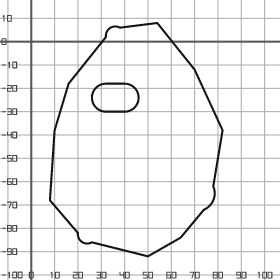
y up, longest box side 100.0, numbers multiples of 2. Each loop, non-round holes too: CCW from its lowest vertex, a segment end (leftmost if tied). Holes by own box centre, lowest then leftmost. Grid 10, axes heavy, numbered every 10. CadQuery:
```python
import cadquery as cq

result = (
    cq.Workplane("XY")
    .moveTo(50.0, -92.0)
    .lineTo(64.0, -84.0)
    .lineTo(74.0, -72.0)
    .threePointArc((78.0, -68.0), (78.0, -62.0))
    .lineTo(82.0, -38.0)
    .lineTo(70.0, -12.0)
    .lineTo(54.0, 8.0)
    .lineTo(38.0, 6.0)
    .threePointArc((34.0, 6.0), (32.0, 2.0))
    .lineTo(16.0, -18.0)
    .lineTo(10.0, -38.0)
    .lineTo(8.0, -68.0)
    .lineTo(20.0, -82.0)
    .threePointArc((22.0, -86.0), (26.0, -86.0))
    .close()
    .moveTo(32.0, -30.0)
    .lineTo(40.0, -30.0)
    .threePointArc((46.0, -24.0), (40.0, -18.0))
    .lineTo(32.0, -18.0)
    .threePointArc((26.0, -24.0), (32.0, -30.0))
    .close()
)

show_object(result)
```